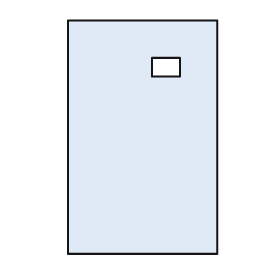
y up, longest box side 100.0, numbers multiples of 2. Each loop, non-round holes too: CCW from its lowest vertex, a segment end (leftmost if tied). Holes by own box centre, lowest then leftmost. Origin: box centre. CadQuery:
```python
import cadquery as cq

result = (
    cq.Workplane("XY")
    .moveTo(-32.0, -50.0)
    .lineTo(32.0, -50.0)
    .lineTo(32.0, 50.0)
    .lineTo(-32.0, 50.0)
    .close()
    .moveTo(4.0, 26.0)
    .lineTo(16.0, 26.0)
    .lineTo(16.0, 34.0)
    .lineTo(4.0, 34.0)
    .close()
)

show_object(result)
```